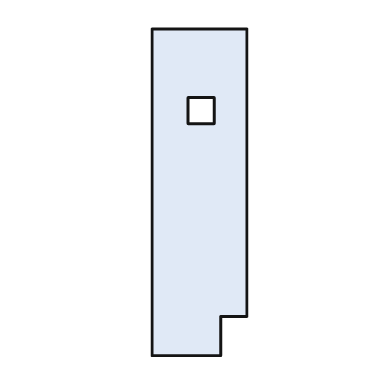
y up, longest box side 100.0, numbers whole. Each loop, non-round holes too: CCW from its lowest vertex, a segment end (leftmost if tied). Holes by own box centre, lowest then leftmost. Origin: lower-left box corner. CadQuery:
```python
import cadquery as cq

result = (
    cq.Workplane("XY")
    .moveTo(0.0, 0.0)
    .lineTo(21.0, 0.0)
    .lineTo(21.0, 12.0)
    .lineTo(29.0, 12.0)
    .lineTo(29.0, 100.0)
    .lineTo(0.0, 100.0)
    .close()
    .moveTo(11.0, 71.0)
    .lineTo(19.0, 71.0)
    .lineTo(19.0, 79.0)
    .lineTo(11.0, 79.0)
    .close()
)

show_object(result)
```